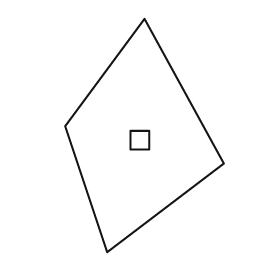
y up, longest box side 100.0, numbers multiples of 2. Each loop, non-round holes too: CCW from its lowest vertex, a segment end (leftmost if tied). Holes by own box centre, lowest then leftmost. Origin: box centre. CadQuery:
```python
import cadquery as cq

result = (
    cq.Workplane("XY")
    .moveTo(-16.0, -50.0)
    .lineTo(34.0, -12.0)
    .lineTo(0.0, 50.0)
    .lineTo(-34.0, 4.0)
    .close()
    .moveTo(-6.0, -6.0)
    .lineTo(2.0, -6.0)
    .lineTo(2.0, 2.0)
    .lineTo(-6.0, 2.0)
    .close()
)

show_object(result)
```